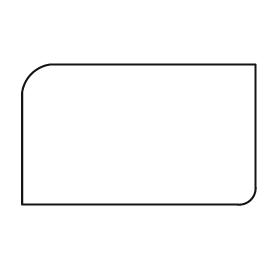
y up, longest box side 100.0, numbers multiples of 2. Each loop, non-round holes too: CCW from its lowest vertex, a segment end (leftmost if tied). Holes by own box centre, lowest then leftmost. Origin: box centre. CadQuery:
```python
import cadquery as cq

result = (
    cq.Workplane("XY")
    .moveTo(-50.0, -30.0)
    .lineTo(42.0, -30.0)
    .threePointArc((48.0, -28.0), (50.0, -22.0))
    .lineTo(50.0, 30.0)
    .lineTo(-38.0, 30.0)
    .threePointArc((-46.0, 26.0), (-50.0, 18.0))
    .close()
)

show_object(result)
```